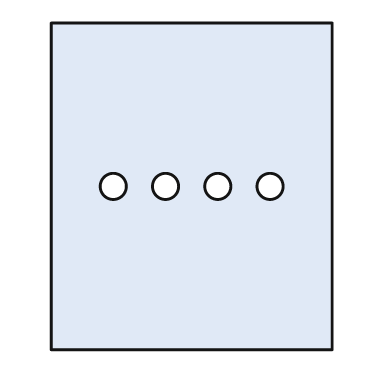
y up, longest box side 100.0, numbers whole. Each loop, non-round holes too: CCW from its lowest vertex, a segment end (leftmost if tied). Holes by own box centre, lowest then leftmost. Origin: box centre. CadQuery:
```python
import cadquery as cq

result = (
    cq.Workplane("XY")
    .moveTo(-43.0, -50.0)
    .lineTo(43.0, -50.0)
    .lineTo(43.0, 50.0)
    .lineTo(-43.0, 50.0)
    .close()
    .moveTo(-24.0, 0.0)
    .circle(4.0)
    .moveTo(-8.0, 0.0)
    .circle(4.0)
    .moveTo(8.0, 0.0)
    .circle(4.0)
    .moveTo(24.0, 0.0)
    .circle(4.0)
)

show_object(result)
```